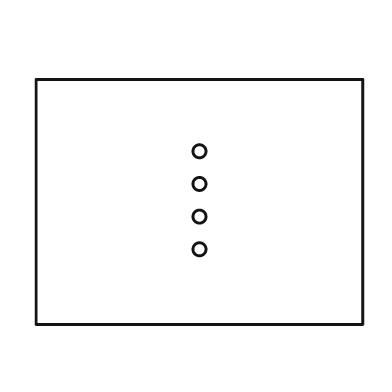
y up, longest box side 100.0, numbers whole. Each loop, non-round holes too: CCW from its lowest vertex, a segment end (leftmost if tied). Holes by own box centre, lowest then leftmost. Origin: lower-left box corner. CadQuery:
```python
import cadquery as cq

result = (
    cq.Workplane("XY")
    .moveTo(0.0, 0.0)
    .lineTo(100.0, 0.0)
    .lineTo(100.0, 75.0)
    .lineTo(0.0, 75.0)
    .close()
    .moveTo(50.0, 23.0)
    .circle(2.0)
    .moveTo(50.0, 33.0)
    .circle(2.0)
    .moveTo(50.0, 43.0)
    .circle(2.0)
    .moveTo(50.0, 53.0)
    .circle(2.0)
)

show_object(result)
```